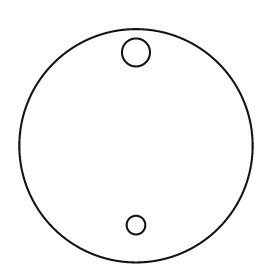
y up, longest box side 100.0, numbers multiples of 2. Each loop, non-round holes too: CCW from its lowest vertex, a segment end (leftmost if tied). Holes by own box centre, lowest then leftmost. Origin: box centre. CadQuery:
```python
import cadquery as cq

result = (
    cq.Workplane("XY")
    .moveTo(0.0, 0.0)
    .circle(50.0)
    .moveTo(0.0, -34.0)
    .circle(4.0)
    .moveTo(0.0, 40.0)
    .circle(6.0)
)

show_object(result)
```